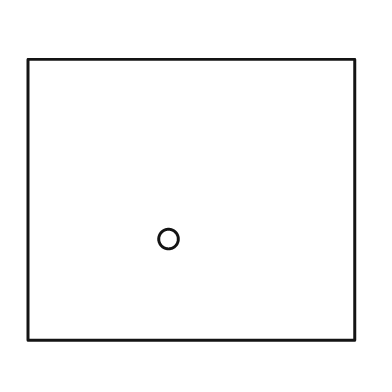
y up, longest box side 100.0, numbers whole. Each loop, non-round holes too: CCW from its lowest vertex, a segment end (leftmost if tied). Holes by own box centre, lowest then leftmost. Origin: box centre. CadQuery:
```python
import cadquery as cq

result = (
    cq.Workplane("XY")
    .moveTo(-50.0, -43.0)
    .lineTo(50.0, -43.0)
    .lineTo(50.0, 43.0)
    .lineTo(-50.0, 43.0)
    .close()
    .moveTo(-7.0, -12.0)
    .circle(3.0)
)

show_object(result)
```